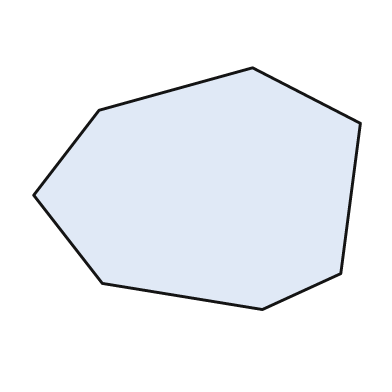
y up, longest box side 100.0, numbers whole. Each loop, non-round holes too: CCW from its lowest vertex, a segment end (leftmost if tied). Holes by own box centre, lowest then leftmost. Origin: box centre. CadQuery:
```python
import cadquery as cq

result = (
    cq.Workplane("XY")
    .moveTo(20.0, -37.0)
    .lineTo(44.0, -26.0)
    .lineTo(50.0, 20.0)
    .lineTo(17.0, 37.0)
    .lineTo(-30.0, 24.0)
    .lineTo(-50.0, -2.0)
    .lineTo(-29.0, -29.0)
    .close()
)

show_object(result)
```